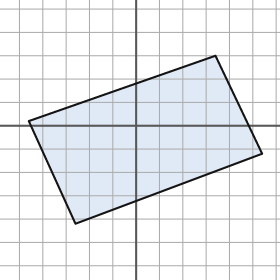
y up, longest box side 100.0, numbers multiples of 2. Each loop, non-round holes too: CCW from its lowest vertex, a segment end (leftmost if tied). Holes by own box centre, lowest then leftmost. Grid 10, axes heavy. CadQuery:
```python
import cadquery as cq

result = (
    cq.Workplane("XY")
    .moveTo(-26.0, -42.0)
    .lineTo(54.0, -12.0)
    .lineTo(34.0, 30.0)
    .lineTo(-46.0, 2.0)
    .close()
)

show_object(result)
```